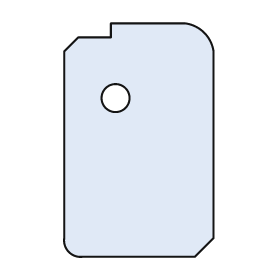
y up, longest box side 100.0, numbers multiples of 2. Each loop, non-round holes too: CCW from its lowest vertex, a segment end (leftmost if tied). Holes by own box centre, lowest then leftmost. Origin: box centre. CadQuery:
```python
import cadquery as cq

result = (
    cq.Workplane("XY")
    .moveTo(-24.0, -50.0)
    .lineTo(24.0, -50.0)
    .lineTo(32.0, -42.0)
    .lineTo(32.0, 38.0)
    .threePointArc((28.0, 46.0), (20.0, 50.0))
    .lineTo(-12.0, 50.0)
    .lineTo(-12.0, 44.0)
    .lineTo(-26.0, 44.0)
    .lineTo(-32.0, 38.0)
    .lineTo(-32.0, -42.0)
    .threePointArc((-30.0, -48.0), (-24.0, -50.0))
    .close()
    .moveTo(-10.0, 18.0)
    .circle(6.0)
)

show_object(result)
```